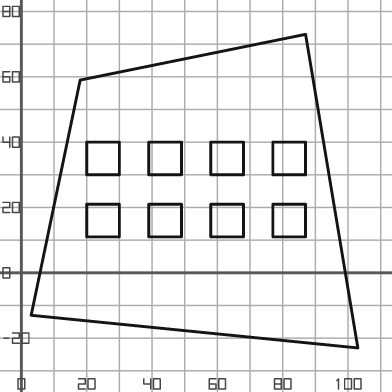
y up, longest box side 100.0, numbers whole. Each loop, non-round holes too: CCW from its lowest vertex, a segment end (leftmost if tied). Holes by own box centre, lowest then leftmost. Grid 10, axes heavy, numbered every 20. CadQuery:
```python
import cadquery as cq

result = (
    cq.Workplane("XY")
    .moveTo(103.0, -23.0)
    .lineTo(87.0, 73.0)
    .lineTo(18.0, 59.0)
    .lineTo(3.0, -13.0)
    .close()
    .moveTo(20.0, 11.0)
    .lineTo(30.0, 11.0)
    .lineTo(30.0, 21.0)
    .lineTo(20.0, 21.0)
    .close()
    .moveTo(39.0, 11.0)
    .lineTo(49.0, 11.0)
    .lineTo(49.0, 21.0)
    .lineTo(39.0, 21.0)
    .close()
    .moveTo(58.0, 11.0)
    .lineTo(68.0, 11.0)
    .lineTo(68.0, 21.0)
    .lineTo(58.0, 21.0)
    .close()
    .moveTo(77.0, 11.0)
    .lineTo(87.0, 11.0)
    .lineTo(87.0, 21.0)
    .lineTo(77.0, 21.0)
    .close()
    .moveTo(20.0, 30.0)
    .lineTo(30.0, 30.0)
    .lineTo(30.0, 40.0)
    .lineTo(20.0, 40.0)
    .close()
    .moveTo(39.0, 30.0)
    .lineTo(49.0, 30.0)
    .lineTo(49.0, 40.0)
    .lineTo(39.0, 40.0)
    .close()
    .moveTo(58.0, 30.0)
    .lineTo(68.0, 30.0)
    .lineTo(68.0, 40.0)
    .lineTo(58.0, 40.0)
    .close()
    .moveTo(77.0, 30.0)
    .lineTo(87.0, 30.0)
    .lineTo(87.0, 40.0)
    .lineTo(77.0, 40.0)
    .close()
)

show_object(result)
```